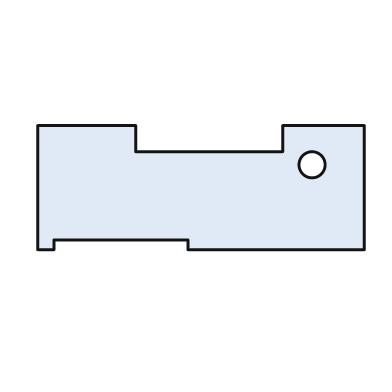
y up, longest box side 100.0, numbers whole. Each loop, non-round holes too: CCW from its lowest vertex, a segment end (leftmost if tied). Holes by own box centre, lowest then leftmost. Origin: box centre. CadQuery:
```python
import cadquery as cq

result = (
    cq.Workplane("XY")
    .moveTo(-50.0, -19.0)
    .lineTo(-45.0, -19.0)
    .lineTo(-45.0, -16.0)
    .lineTo(-4.0, -16.0)
    .lineTo(-4.0, -19.0)
    .lineTo(50.0, -19.0)
    .lineTo(50.0, 19.0)
    .lineTo(25.0, 19.0)
    .lineTo(25.0, 11.0)
    .lineTo(-20.0, 11.0)
    .lineTo(-20.0, 19.0)
    .lineTo(-50.0, 19.0)
    .close()
    .moveTo(34.0, 7.0)
    .circle(4.0)
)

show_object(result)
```